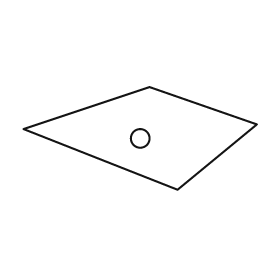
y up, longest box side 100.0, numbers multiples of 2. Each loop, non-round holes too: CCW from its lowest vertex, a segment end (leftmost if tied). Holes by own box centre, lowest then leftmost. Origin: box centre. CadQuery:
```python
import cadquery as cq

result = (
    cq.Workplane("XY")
    .moveTo(16.0, -22.0)
    .lineTo(50.0, 6.0)
    .lineTo(4.0, 22.0)
    .lineTo(-50.0, 4.0)
    .close()
    .moveTo(0.0, 0.0)
    .circle(4.0)
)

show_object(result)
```